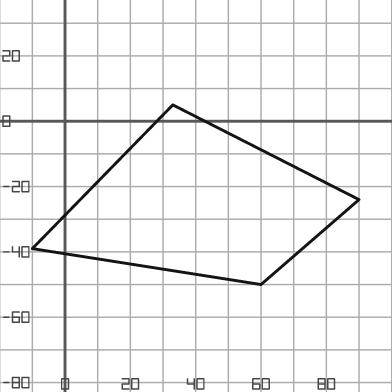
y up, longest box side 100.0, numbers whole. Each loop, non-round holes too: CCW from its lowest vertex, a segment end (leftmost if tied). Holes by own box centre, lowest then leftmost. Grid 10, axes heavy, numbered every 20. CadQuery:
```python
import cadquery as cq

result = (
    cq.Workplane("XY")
    .moveTo(60.0, -50.0)
    .lineTo(90.0, -24.0)
    .lineTo(33.0, 5.0)
    .lineTo(-10.0, -39.0)
    .close()
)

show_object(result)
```